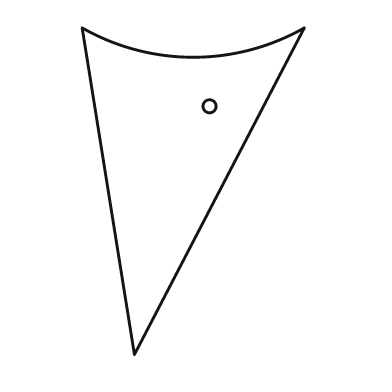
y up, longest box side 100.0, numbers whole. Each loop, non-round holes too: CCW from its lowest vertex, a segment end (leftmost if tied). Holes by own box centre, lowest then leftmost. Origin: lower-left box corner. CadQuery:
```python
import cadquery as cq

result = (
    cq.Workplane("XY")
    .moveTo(16.0, 0.0)
    .lineTo(68.0, 100.0)
    .threePointArc((34.0, 91.0), (0.0, 100.0))
    .close()
    .moveTo(39.0, 76.0)
    .circle(2.0)
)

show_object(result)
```